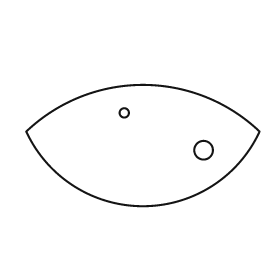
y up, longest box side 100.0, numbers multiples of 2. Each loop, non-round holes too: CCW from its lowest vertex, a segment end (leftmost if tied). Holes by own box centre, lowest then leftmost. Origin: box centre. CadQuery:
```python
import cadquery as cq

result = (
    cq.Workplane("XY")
    .moveTo(-50.0, 6.0)
    .threePointArc((0.0, -26.0), (50.0, 6.0))
    .threePointArc((0.0, 26.0), (-50.0, 6.0))
    .close()
    .moveTo(26.0, -2.0)
    .circle(4.0)
    .moveTo(-8.0, 14.0)
    .circle(2.0)
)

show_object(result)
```